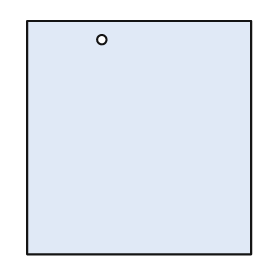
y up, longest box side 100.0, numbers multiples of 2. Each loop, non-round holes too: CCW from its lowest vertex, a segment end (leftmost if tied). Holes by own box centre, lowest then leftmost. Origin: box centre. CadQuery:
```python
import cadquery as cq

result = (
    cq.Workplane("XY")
    .moveTo(-48.0, -50.0)
    .lineTo(48.0, -50.0)
    .lineTo(48.0, 50.0)
    .lineTo(-48.0, 50.0)
    .close()
    .moveTo(-16.0, 42.0)
    .circle(2.0)
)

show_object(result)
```